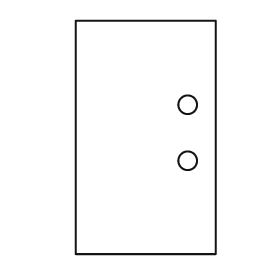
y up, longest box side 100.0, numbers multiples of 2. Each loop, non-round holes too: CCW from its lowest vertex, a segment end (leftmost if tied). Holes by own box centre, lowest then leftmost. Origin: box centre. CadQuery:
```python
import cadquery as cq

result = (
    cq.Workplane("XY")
    .moveTo(-30.0, -50.0)
    .lineTo(30.0, -50.0)
    .lineTo(30.0, 50.0)
    .lineTo(-30.0, 50.0)
    .close()
    .moveTo(18.0, -10.0)
    .circle(4.0)
    .moveTo(18.0, 14.0)
    .circle(4.0)
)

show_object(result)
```